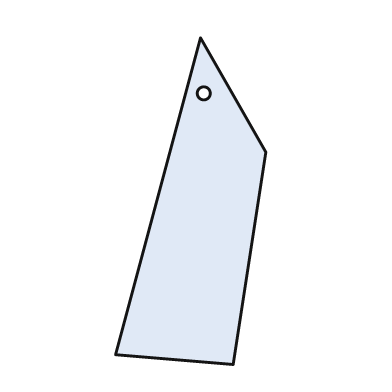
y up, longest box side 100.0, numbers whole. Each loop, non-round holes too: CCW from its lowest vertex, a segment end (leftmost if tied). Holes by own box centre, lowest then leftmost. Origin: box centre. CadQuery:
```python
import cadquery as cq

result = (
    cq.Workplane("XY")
    .moveTo(13.0, -50.0)
    .lineTo(23.0, 15.0)
    .lineTo(3.0, 50.0)
    .lineTo(-23.0, -47.0)
    .close()
    .moveTo(4.0, 33.0)
    .circle(2.0)
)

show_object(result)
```